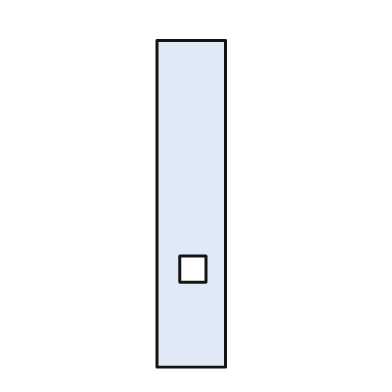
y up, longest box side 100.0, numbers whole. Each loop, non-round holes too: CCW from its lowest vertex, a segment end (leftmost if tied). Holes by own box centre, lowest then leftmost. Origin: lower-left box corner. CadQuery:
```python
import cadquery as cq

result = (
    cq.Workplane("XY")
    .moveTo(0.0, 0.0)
    .lineTo(21.0, 0.0)
    .lineTo(21.0, 100.0)
    .lineTo(0.0, 100.0)
    .close()
    .moveTo(7.0, 26.0)
    .lineTo(15.0, 26.0)
    .lineTo(15.0, 34.0)
    .lineTo(7.0, 34.0)
    .close()
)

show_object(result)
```